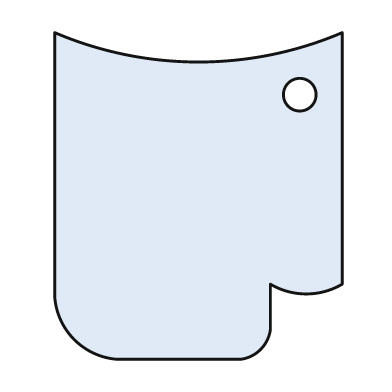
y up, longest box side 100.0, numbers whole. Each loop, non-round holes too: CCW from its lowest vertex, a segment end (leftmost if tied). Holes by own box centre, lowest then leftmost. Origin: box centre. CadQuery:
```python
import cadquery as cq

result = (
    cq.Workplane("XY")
    .moveTo(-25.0, -50.0)
    .lineTo(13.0, -50.0)
    .threePointArc((19.0, -47.0), (22.0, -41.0))
    .lineTo(22.0, -27.0)
    .threePointArc((33.0, -30.0), (44.0, -27.0))
    .lineTo(44.0, 50.0)
    .threePointArc((0.0, 41.0), (-44.0, 50.0))
    .lineTo(-44.0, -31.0)
    .threePointArc((-38.0, -44.0), (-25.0, -50.0))
    .close()
    .moveTo(31.0, 31.0)
    .circle(5.0)
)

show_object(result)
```